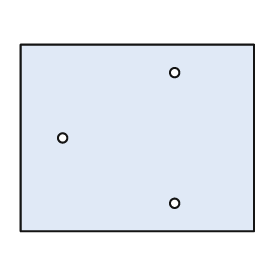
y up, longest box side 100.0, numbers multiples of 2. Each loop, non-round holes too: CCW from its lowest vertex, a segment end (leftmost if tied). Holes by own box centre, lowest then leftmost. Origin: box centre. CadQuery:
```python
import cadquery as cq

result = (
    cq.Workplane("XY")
    .moveTo(-50.0, -40.0)
    .lineTo(50.0, -40.0)
    .lineTo(50.0, 40.0)
    .lineTo(-50.0, 40.0)
    .close()
    .moveTo(16.0, -28.0)
    .circle(2.0)
    .moveTo(-32.0, 0.0)
    .circle(2.0)
    .moveTo(16.0, 28.0)
    .circle(2.0)
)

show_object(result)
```